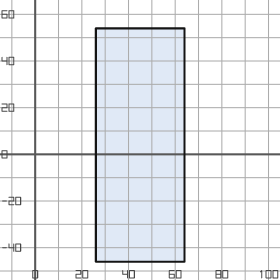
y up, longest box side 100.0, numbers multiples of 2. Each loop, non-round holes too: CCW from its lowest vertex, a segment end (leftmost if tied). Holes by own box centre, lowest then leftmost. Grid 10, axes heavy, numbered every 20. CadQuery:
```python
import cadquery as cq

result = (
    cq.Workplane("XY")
    .moveTo(26.0, -46.0)
    .lineTo(64.0, -46.0)
    .lineTo(64.0, 54.0)
    .lineTo(26.0, 54.0)
    .close()
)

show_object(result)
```